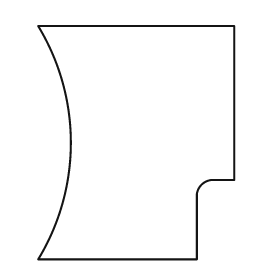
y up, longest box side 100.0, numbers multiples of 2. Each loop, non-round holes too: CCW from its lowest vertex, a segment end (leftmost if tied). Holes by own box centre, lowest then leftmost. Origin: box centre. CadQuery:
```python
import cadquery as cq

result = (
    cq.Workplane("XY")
    .moveTo(-42.0, -50.0)
    .lineTo(26.0, -50.0)
    .lineTo(26.0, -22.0)
    .threePointArc((28.0, -18.0), (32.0, -16.0))
    .lineTo(42.0, -16.0)
    .lineTo(42.0, 50.0)
    .lineTo(-42.0, 50.0)
    .threePointArc((-28.0, 0.0), (-42.0, -50.0))
    .close()
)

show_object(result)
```